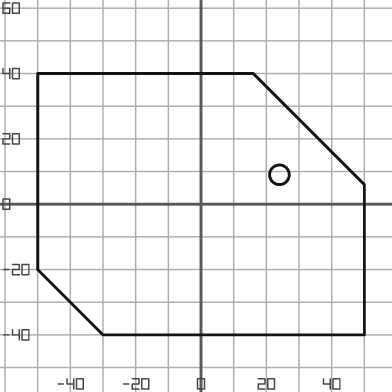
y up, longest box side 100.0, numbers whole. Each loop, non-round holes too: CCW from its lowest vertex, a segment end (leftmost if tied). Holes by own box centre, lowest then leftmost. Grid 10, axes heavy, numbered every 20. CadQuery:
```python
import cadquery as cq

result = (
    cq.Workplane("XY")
    .moveTo(-30.0, -40.0)
    .lineTo(50.0, -40.0)
    .lineTo(50.0, 6.0)
    .lineTo(16.0, 40.0)
    .lineTo(-50.0, 40.0)
    .lineTo(-50.0, -20.0)
    .close()
    .moveTo(24.0, 9.0)
    .circle(3.0)
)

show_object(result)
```